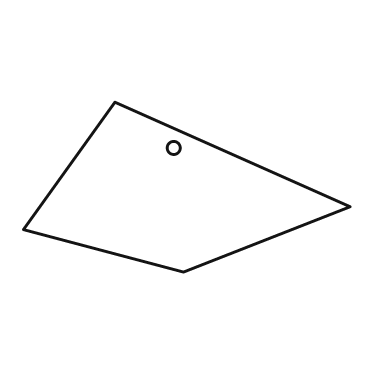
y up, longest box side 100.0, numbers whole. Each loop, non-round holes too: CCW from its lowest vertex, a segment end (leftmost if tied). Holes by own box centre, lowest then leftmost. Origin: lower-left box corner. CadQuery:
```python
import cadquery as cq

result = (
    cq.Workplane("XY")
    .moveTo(49.0, 0.0)
    .lineTo(100.0, 20.0)
    .lineTo(28.0, 52.0)
    .lineTo(0.0, 13.0)
    .close()
    .moveTo(46.0, 38.0)
    .circle(2.0)
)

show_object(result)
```